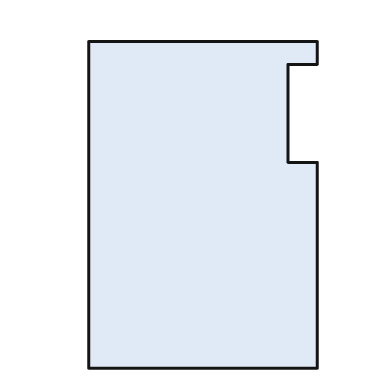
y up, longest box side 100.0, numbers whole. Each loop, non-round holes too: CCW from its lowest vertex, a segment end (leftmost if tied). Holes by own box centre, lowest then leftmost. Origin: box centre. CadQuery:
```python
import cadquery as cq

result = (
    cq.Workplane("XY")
    .moveTo(-35.0, -50.0)
    .lineTo(35.0, -50.0)
    .lineTo(35.0, 13.0)
    .lineTo(26.0, 13.0)
    .lineTo(26.0, 43.0)
    .lineTo(35.0, 43.0)
    .lineTo(35.0, 50.0)
    .lineTo(-35.0, 50.0)
    .close()
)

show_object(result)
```